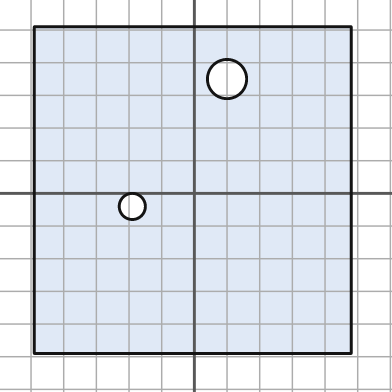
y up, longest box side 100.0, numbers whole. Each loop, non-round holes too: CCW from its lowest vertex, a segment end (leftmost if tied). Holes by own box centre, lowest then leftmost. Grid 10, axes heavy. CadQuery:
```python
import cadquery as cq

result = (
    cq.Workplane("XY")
    .moveTo(-49.0, -49.0)
    .lineTo(48.0, -49.0)
    .lineTo(48.0, 51.0)
    .lineTo(-49.0, 51.0)
    .close()
    .moveTo(-19.0, -4.0)
    .circle(4.0)
    .moveTo(10.0, 35.0)
    .circle(6.0)
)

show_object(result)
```